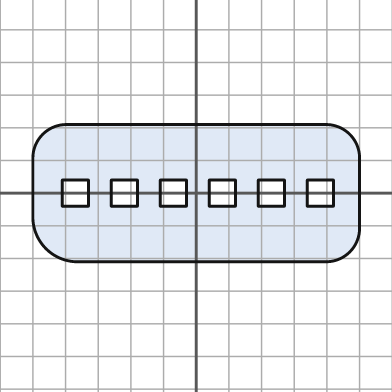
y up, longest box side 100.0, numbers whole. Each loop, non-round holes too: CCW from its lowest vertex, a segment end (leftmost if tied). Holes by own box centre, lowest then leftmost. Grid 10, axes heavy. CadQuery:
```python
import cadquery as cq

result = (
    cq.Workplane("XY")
    .moveTo(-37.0, -21.0)
    .lineTo(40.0, -21.0)
    .threePointArc((47.0, -18.0), (50.0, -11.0))
    .lineTo(50.0, 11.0)
    .threePointArc((47.0, 18.0), (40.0, 21.0))
    .lineTo(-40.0, 21.0)
    .threePointArc((-47.0, 18.0), (-50.0, 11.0))
    .lineTo(-50.0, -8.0)
    .threePointArc((-46.0, -17.0), (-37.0, -21.0))
    .close()
    .moveTo(-41.0, -4.0)
    .lineTo(-33.0, -4.0)
    .lineTo(-33.0, 4.0)
    .lineTo(-41.0, 4.0)
    .close()
    .moveTo(-26.0, -4.0)
    .lineTo(-18.0, -4.0)
    .lineTo(-18.0, 4.0)
    .lineTo(-26.0, 4.0)
    .close()
    .moveTo(-11.0, -4.0)
    .lineTo(-3.0, -4.0)
    .lineTo(-3.0, 4.0)
    .lineTo(-11.0, 4.0)
    .close()
    .moveTo(4.0, -4.0)
    .lineTo(12.0, -4.0)
    .lineTo(12.0, 4.0)
    .lineTo(4.0, 4.0)
    .close()
    .moveTo(19.0, -4.0)
    .lineTo(27.0, -4.0)
    .lineTo(27.0, 4.0)
    .lineTo(19.0, 4.0)
    .close()
    .moveTo(34.0, -4.0)
    .lineTo(42.0, -4.0)
    .lineTo(42.0, 4.0)
    .lineTo(34.0, 4.0)
    .close()
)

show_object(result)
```